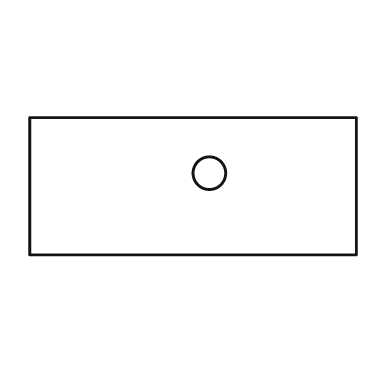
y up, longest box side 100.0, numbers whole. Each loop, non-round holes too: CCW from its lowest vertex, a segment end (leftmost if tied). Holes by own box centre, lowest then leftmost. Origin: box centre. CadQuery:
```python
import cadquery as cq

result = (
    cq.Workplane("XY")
    .moveTo(-50.0, -21.0)
    .lineTo(50.0, -21.0)
    .lineTo(50.0, 21.0)
    .lineTo(-50.0, 21.0)
    .close()
    .moveTo(5.0, 4.0)
    .circle(5.0)
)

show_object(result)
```